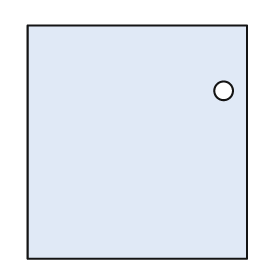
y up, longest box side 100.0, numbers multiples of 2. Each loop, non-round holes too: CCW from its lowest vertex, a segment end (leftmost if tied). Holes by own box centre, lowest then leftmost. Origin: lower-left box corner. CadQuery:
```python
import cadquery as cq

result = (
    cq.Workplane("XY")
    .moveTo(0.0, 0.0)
    .lineTo(94.0, 0.0)
    .lineTo(94.0, 100.0)
    .lineTo(0.0, 100.0)
    .close()
    .moveTo(84.0, 72.0)
    .circle(4.0)
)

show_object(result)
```